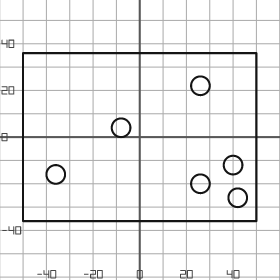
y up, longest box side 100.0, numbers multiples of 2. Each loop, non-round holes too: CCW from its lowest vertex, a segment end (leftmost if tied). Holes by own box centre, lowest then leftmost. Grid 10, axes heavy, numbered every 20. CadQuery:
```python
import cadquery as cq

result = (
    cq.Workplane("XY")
    .moveTo(-50.0, -36.0)
    .lineTo(50.0, -36.0)
    .lineTo(50.0, 36.0)
    .lineTo(-50.0, 36.0)
    .close()
    .moveTo(42.0, -26.0)
    .circle(4.0)
    .moveTo(26.0, -20.0)
    .circle(4.0)
    .moveTo(-36.0, -16.0)
    .circle(4.0)
    .moveTo(40.0, -12.0)
    .circle(4.0)
    .moveTo(-8.0, 4.0)
    .circle(4.0)
    .moveTo(26.0, 22.0)
    .circle(4.0)
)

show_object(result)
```